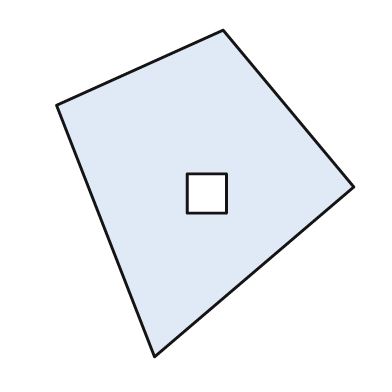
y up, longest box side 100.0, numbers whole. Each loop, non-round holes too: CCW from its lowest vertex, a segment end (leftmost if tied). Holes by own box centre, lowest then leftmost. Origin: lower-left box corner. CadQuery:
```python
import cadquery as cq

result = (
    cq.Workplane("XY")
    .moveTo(30.0, 0.0)
    .lineTo(91.0, 52.0)
    .lineTo(51.0, 100.0)
    .lineTo(0.0, 77.0)
    .close()
    .moveTo(40.0, 44.0)
    .lineTo(52.0, 44.0)
    .lineTo(52.0, 56.0)
    .lineTo(40.0, 56.0)
    .close()
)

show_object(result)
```